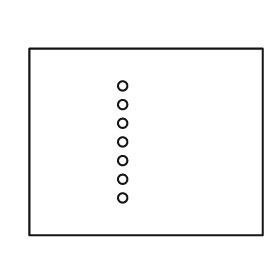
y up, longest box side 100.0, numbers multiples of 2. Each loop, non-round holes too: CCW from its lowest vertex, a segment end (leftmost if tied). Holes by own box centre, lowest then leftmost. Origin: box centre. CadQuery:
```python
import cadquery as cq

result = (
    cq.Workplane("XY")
    .moveTo(-50.0, -40.0)
    .lineTo(50.0, -40.0)
    .lineTo(50.0, 40.0)
    .lineTo(-50.0, 40.0)
    .close()
    .moveTo(-10.0, -24.0)
    .circle(2.0)
    .moveTo(-10.0, -16.0)
    .circle(2.0)
    .moveTo(-10.0, -8.0)
    .circle(2.0)
    .moveTo(-10.0, 0.0)
    .circle(2.0)
    .moveTo(-10.0, 8.0)
    .circle(2.0)
    .moveTo(-10.0, 16.0)
    .circle(2.0)
    .moveTo(-10.0, 24.0)
    .circle(2.0)
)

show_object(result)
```